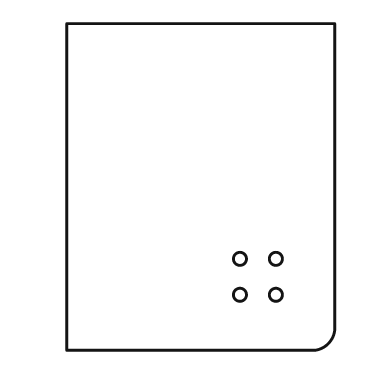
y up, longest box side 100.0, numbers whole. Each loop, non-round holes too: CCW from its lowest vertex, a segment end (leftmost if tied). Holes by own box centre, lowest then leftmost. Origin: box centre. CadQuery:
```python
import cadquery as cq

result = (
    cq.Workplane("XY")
    .moveTo(-41.0, -50.0)
    .lineTo(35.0, -50.0)
    .threePointArc((39.0, -48.0), (41.0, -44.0))
    .lineTo(41.0, 50.0)
    .lineTo(-41.0, 50.0)
    .close()
    .moveTo(12.0, -33.0)
    .circle(2.0)
    .moveTo(23.0, -33.0)
    .circle(2.0)
    .moveTo(12.0, -22.0)
    .circle(2.0)
    .moveTo(23.0, -22.0)
    .circle(2.0)
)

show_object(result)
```